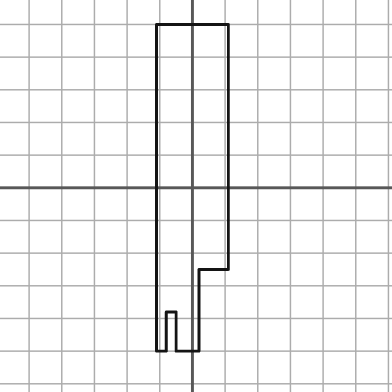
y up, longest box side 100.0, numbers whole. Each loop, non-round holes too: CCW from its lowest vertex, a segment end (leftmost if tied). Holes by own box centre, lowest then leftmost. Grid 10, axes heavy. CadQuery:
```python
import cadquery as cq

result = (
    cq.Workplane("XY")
    .moveTo(-11.0, -50.0)
    .lineTo(-8.0, -50.0)
    .lineTo(-8.0, -38.0)
    .lineTo(-5.0, -38.0)
    .lineTo(-5.0, -50.0)
    .lineTo(2.0, -50.0)
    .lineTo(2.0, -25.0)
    .lineTo(11.0, -25.0)
    .lineTo(11.0, 50.0)
    .lineTo(-11.0, 50.0)
    .close()
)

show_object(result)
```